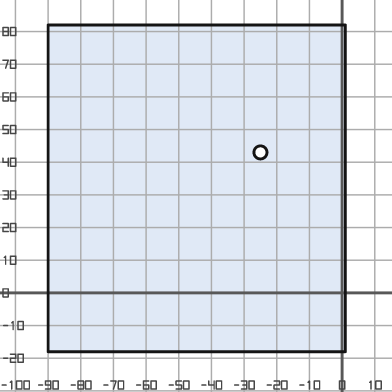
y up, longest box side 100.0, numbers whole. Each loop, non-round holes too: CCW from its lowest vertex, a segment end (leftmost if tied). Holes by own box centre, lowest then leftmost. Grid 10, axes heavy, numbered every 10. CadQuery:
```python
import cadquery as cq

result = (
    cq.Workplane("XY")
    .moveTo(-90.0, -18.0)
    .lineTo(1.0, -18.0)
    .lineTo(1.0, 82.0)
    .lineTo(-90.0, 82.0)
    .close()
    .moveTo(-25.0, 43.0)
    .circle(2.0)
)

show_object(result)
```